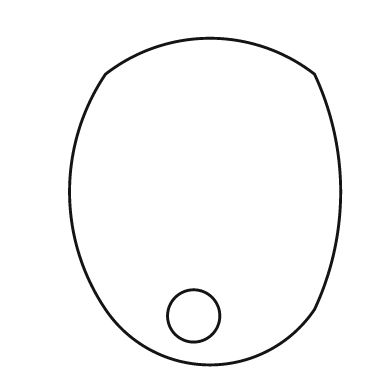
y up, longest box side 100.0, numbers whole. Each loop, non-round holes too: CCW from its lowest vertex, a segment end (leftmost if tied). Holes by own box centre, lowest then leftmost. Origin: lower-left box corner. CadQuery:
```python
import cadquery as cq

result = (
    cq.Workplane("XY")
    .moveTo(11.0, 17.0)
    .threePointArc((43.0, 0.0), (75.0, 17.0))
    .threePointArc((83.0, 53.0), (75.0, 89.0))
    .threePointArc((43.0, 100.0), (11.0, 89.0))
    .threePointArc((0.0, 53.0), (11.0, 17.0))
    .close()
    .moveTo(38.0, 15.0)
    .circle(8.0)
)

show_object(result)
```